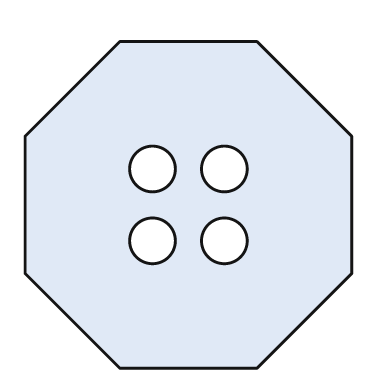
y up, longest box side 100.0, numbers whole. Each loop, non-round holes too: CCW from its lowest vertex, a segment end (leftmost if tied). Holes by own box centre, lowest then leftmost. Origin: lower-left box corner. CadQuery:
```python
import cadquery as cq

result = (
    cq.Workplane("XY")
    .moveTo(29.0, 0.0)
    .lineTo(71.0, 0.0)
    .lineTo(100.0, 29.0)
    .lineTo(100.0, 71.0)
    .lineTo(71.0, 100.0)
    .lineTo(29.0, 100.0)
    .lineTo(0.0, 71.0)
    .lineTo(0.0, 29.0)
    .close()
    .moveTo(39.0, 39.0)
    .circle(7.0)
    .moveTo(61.0, 39.0)
    .circle(7.0)
    .moveTo(39.0, 61.0)
    .circle(7.0)
    .moveTo(61.0, 61.0)
    .circle(7.0)
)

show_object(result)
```